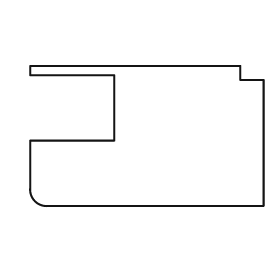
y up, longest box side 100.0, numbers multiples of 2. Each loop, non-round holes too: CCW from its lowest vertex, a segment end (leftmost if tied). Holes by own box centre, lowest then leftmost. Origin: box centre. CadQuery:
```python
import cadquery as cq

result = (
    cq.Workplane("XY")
    .moveTo(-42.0, -30.0)
    .lineTo(50.0, -30.0)
    .lineTo(50.0, 24.0)
    .lineTo(40.0, 24.0)
    .lineTo(40.0, 30.0)
    .lineTo(-50.0, 30.0)
    .lineTo(-50.0, 26.0)
    .lineTo(-14.0, 26.0)
    .lineTo(-14.0, -2.0)
    .lineTo(-50.0, -2.0)
    .lineTo(-50.0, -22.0)
    .threePointArc((-48.0, -28.0), (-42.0, -30.0))
    .close()
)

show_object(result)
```